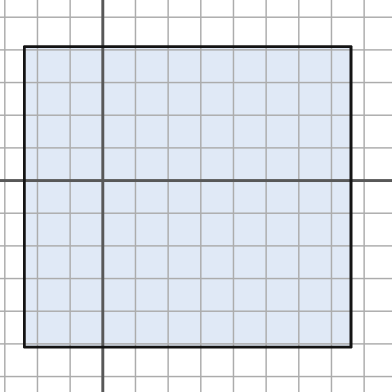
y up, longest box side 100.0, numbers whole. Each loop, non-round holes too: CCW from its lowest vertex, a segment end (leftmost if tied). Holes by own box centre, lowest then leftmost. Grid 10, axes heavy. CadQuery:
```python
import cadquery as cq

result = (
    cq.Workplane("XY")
    .moveTo(-24.0, -51.0)
    .lineTo(76.0, -51.0)
    .lineTo(76.0, 41.0)
    .lineTo(-24.0, 41.0)
    .close()
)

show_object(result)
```